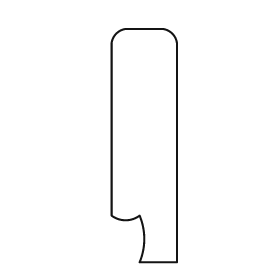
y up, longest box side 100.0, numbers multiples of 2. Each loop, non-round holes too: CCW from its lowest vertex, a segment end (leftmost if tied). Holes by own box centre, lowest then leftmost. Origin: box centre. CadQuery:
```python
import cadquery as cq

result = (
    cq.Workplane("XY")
    .moveTo(-2.0, -50.0)
    .lineTo(14.0, -50.0)
    .lineTo(14.0, 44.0)
    .threePointArc((12.0, 48.0), (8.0, 50.0))
    .lineTo(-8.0, 50.0)
    .threePointArc((-12.0, 48.0), (-14.0, 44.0))
    .lineTo(-14.0, -30.0)
    .threePointArc((-8.0, -32.0), (-2.0, -30.0))
    .threePointArc((0.0, -40.0), (-2.0, -50.0))
    .close()
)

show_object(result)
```